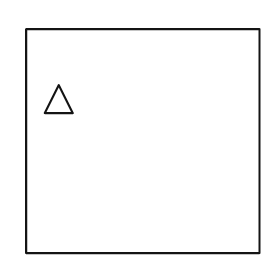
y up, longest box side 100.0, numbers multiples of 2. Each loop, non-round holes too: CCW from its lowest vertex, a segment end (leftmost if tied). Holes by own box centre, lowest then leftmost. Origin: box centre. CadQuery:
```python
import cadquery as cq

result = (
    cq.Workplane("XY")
    .moveTo(-50.0, -48.0)
    .lineTo(50.0, -48.0)
    .lineTo(50.0, 48.0)
    .lineTo(-50.0, 48.0)
    .close()
    .moveTo(-42.0, 12.0)
    .lineTo(-30.0, 12.0)
    .lineTo(-36.0, 24.0)
    .close()
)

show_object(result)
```